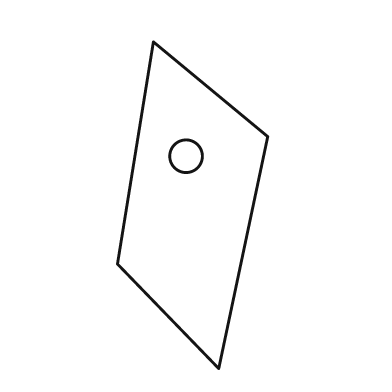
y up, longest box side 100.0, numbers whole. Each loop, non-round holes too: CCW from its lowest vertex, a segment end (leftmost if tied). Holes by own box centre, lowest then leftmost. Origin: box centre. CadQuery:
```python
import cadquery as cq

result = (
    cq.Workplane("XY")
    .moveTo(8.0, -50.0)
    .lineTo(23.0, 21.0)
    .lineTo(-12.0, 50.0)
    .lineTo(-23.0, -18.0)
    .close()
    .moveTo(-2.0, 15.0)
    .circle(5.0)
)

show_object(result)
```